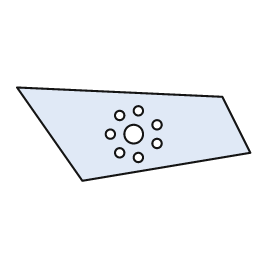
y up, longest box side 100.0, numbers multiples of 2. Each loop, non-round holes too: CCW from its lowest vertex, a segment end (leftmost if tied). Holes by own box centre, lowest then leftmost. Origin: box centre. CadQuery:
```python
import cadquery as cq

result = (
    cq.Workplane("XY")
    .moveTo(-22.0, -20.0)
    .lineTo(50.0, -8.0)
    .lineTo(38.0, 16.0)
    .lineTo(-50.0, 20.0)
    .close()
    .moveTo(2.0, -10.0)
    .circle(2.0)
    .moveTo(-6.0, -8.0)
    .circle(2.0)
    .moveTo(10.0, -4.0)
    .circle(2.0)
    .moveTo(-10.0, 0.0)
    .circle(2.0)
    .moveTo(0.0, 0.0)
    .circle(4.0)
    .moveTo(10.0, 4.0)
    .circle(2.0)
    .moveTo(-6.0, 8.0)
    .circle(2.0)
    .moveTo(2.0, 10.0)
    .circle(2.0)
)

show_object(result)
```